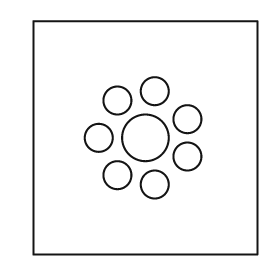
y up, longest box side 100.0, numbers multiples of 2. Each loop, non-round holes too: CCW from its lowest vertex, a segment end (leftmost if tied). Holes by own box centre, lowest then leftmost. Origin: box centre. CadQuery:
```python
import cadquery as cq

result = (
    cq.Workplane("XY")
    .moveTo(-48.0, -50.0)
    .lineTo(48.0, -50.0)
    .lineTo(48.0, 50.0)
    .lineTo(-48.0, 50.0)
    .close()
    .moveTo(4.0, -20.0)
    .circle(6.0)
    .moveTo(-12.0, -16.0)
    .circle(6.0)
    .moveTo(18.0, -8.0)
    .circle(6.0)
    .moveTo(-20.0, 0.0)
    .circle(6.0)
    .moveTo(0.0, 0.0)
    .circle(10.0)
    .moveTo(18.0, 8.0)
    .circle(6.0)
    .moveTo(-12.0, 16.0)
    .circle(6.0)
    .moveTo(4.0, 20.0)
    .circle(6.0)
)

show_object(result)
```